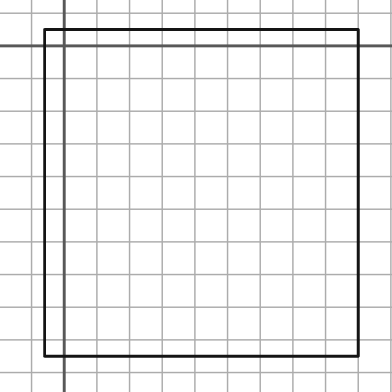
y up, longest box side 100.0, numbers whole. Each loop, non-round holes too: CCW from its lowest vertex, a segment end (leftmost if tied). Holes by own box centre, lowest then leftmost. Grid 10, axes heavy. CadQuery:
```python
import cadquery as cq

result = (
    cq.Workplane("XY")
    .moveTo(-6.0, -95.0)
    .lineTo(90.0, -95.0)
    .lineTo(90.0, 5.0)
    .lineTo(-6.0, 5.0)
    .close()
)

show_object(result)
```